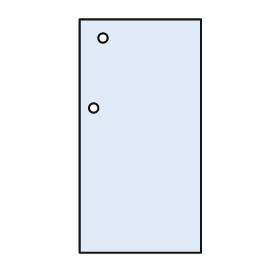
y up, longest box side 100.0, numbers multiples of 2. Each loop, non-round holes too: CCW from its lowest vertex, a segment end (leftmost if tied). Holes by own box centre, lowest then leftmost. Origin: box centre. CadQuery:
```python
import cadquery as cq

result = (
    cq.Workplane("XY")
    .moveTo(-26.0, -50.0)
    .lineTo(26.0, -50.0)
    .lineTo(26.0, 50.0)
    .lineTo(-26.0, 50.0)
    .close()
    .moveTo(-20.0, 12.0)
    .circle(2.0)
    .moveTo(-16.0, 42.0)
    .circle(2.0)
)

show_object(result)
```